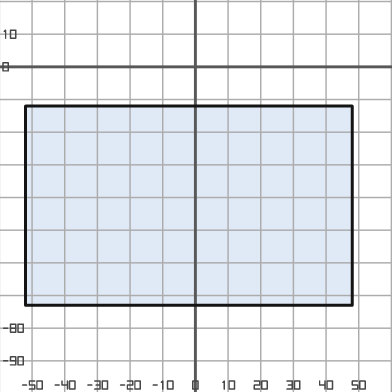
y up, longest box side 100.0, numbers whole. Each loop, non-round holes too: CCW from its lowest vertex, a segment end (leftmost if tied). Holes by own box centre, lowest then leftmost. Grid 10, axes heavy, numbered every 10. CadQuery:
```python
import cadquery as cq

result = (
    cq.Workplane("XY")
    .moveTo(-52.0, -73.0)
    .lineTo(48.0, -73.0)
    .lineTo(48.0, -12.0)
    .lineTo(-52.0, -12.0)
    .close()
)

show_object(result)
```